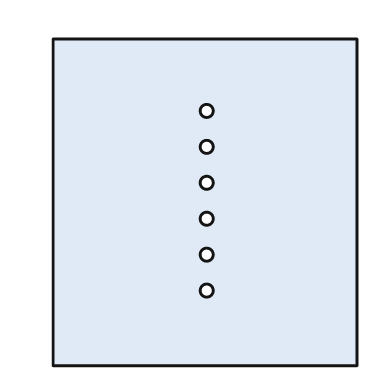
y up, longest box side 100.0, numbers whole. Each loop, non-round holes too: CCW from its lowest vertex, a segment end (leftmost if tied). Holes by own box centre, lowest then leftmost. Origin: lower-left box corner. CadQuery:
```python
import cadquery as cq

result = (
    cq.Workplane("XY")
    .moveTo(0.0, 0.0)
    .lineTo(93.0, 0.0)
    .lineTo(93.0, 100.0)
    .lineTo(0.0, 100.0)
    .close()
    .moveTo(47.0, 23.0)
    .circle(2.0)
    .moveTo(47.0, 34.0)
    .circle(2.0)
    .moveTo(47.0, 45.0)
    .circle(2.0)
    .moveTo(47.0, 56.0)
    .circle(2.0)
    .moveTo(47.0, 67.0)
    .circle(2.0)
    .moveTo(47.0, 78.0)
    .circle(2.0)
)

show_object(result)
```